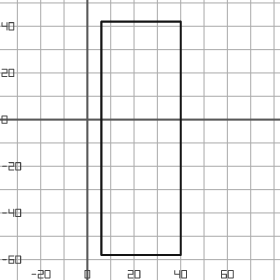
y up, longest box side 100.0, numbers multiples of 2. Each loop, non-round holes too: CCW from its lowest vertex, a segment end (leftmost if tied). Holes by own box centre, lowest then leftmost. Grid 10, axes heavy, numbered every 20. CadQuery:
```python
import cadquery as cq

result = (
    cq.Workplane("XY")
    .moveTo(6.0, -58.0)
    .lineTo(40.0, -58.0)
    .lineTo(40.0, 42.0)
    .lineTo(6.0, 42.0)
    .close()
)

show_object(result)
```